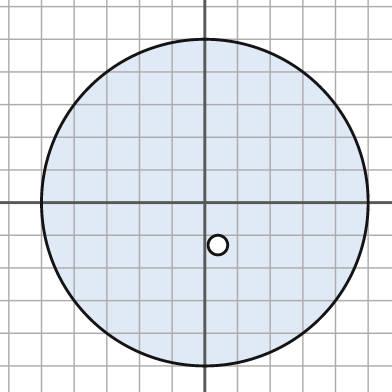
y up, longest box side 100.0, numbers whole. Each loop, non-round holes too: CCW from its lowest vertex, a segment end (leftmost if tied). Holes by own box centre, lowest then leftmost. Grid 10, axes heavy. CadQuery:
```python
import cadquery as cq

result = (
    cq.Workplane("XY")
    .moveTo(0.0, 0.0)
    .circle(50.0)
    .moveTo(4.0, -13.0)
    .circle(3.0)
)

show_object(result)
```